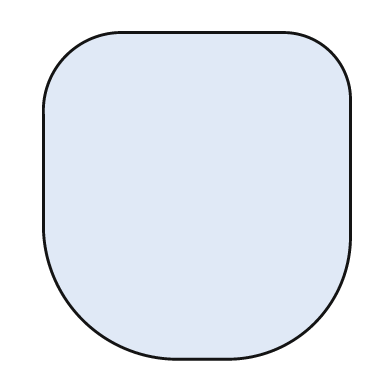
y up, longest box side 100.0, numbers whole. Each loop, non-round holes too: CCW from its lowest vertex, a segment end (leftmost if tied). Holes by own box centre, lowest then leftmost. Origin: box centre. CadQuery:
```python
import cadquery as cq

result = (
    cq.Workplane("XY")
    .moveTo(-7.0, -50.0)
    .lineTo(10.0, -50.0)
    .threePointArc((36.0, -39.0), (47.0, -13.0))
    .lineTo(47.0, 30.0)
    .threePointArc((41.0, 44.0), (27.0, 50.0))
    .lineTo(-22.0, 50.0)
    .threePointArc((-40.0, 43.0), (-47.0, 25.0))
    .lineTo(-47.0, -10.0)
    .threePointArc((-35.0, -38.0), (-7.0, -50.0))
    .close()
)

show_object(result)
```